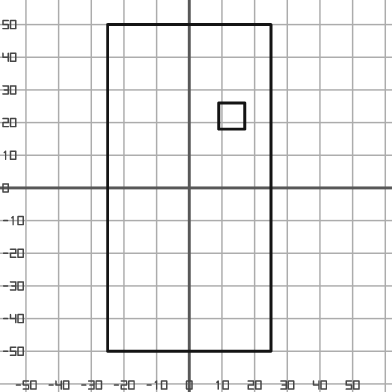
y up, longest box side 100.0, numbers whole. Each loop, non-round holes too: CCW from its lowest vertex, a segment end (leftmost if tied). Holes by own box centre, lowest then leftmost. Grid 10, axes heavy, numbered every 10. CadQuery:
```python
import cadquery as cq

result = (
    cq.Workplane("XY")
    .moveTo(-25.0, -50.0)
    .lineTo(25.0, -50.0)
    .lineTo(25.0, 50.0)
    .lineTo(-25.0, 50.0)
    .close()
    .moveTo(9.0, 18.0)
    .lineTo(17.0, 18.0)
    .lineTo(17.0, 26.0)
    .lineTo(9.0, 26.0)
    .close()
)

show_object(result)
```